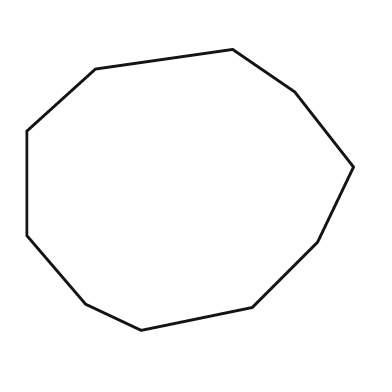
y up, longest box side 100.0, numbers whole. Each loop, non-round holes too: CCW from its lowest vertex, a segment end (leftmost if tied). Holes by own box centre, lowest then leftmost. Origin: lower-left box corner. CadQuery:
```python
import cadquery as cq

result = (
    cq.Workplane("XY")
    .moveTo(35.0, 0.0)
    .lineTo(69.0, 7.0)
    .lineTo(89.0, 27.0)
    .lineTo(100.0, 50.0)
    .lineTo(82.0, 73.0)
    .lineTo(63.0, 86.0)
    .lineTo(21.0, 80.0)
    .lineTo(0.0, 61.0)
    .lineTo(0.0, 29.0)
    .lineTo(18.0, 8.0)
    .close()
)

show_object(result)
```